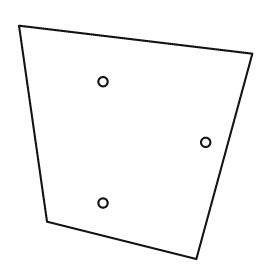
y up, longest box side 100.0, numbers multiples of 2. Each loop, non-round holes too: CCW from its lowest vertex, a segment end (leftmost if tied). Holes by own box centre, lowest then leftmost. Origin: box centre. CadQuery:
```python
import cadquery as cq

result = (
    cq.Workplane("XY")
    .moveTo(26.0, -50.0)
    .lineTo(50.0, 38.0)
    .lineTo(-50.0, 50.0)
    .lineTo(-38.0, -34.0)
    .close()
    .moveTo(-14.0, -26.0)
    .circle(2.0)
    .moveTo(30.0, 0.0)
    .circle(2.0)
    .moveTo(-14.0, 26.0)
    .circle(2.0)
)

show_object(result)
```